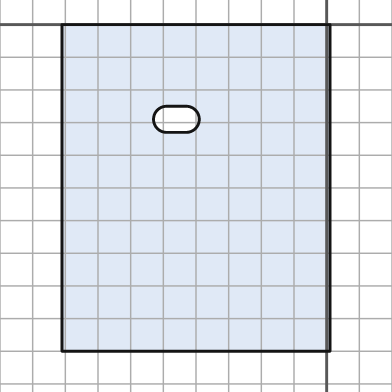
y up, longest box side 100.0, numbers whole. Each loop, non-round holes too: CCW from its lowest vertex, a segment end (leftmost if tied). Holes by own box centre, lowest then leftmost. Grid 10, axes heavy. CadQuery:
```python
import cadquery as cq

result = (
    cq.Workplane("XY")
    .moveTo(-81.0, -100.0)
    .lineTo(1.0, -100.0)
    .lineTo(1.0, 0.0)
    .lineTo(-81.0, 0.0)
    .close()
    .moveTo(-49.0, -33.0)
    .lineTo(-43.0, -33.0)
    .threePointArc((-39.0, -29.0), (-43.0, -25.0))
    .lineTo(-49.0, -25.0)
    .threePointArc((-53.0, -29.0), (-49.0, -33.0))
    .close()
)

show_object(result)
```